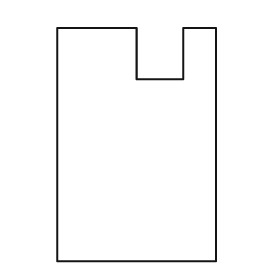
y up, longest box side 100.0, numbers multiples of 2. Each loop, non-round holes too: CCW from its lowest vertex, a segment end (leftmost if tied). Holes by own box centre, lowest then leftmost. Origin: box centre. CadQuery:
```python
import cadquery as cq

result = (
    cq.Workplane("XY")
    .moveTo(-34.0, -50.0)
    .lineTo(34.0, -50.0)
    .lineTo(34.0, 50.0)
    .lineTo(20.0, 50.0)
    .lineTo(20.0, 28.0)
    .lineTo(0.0, 28.0)
    .lineTo(0.0, 50.0)
    .lineTo(-34.0, 50.0)
    .close()
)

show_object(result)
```